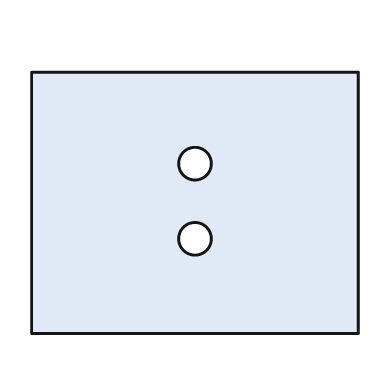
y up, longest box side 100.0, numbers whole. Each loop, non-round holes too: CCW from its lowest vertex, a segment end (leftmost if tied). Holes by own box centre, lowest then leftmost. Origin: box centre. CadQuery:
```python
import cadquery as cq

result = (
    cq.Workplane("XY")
    .moveTo(-50.0, -40.0)
    .lineTo(50.0, -40.0)
    .lineTo(50.0, 40.0)
    .lineTo(-50.0, 40.0)
    .close()
    .moveTo(0.0, -11.0)
    .circle(5.0)
    .moveTo(0.0, 12.0)
    .circle(5.0)
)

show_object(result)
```